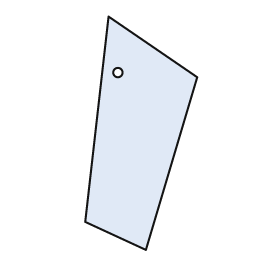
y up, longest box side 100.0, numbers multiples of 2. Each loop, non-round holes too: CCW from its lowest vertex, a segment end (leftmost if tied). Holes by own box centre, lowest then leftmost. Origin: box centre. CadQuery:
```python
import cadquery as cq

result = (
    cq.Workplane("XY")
    .moveTo(2.0, -50.0)
    .lineTo(24.0, 24.0)
    .lineTo(-14.0, 50.0)
    .lineTo(-24.0, -38.0)
    .close()
    .moveTo(-10.0, 26.0)
    .circle(2.0)
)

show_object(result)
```